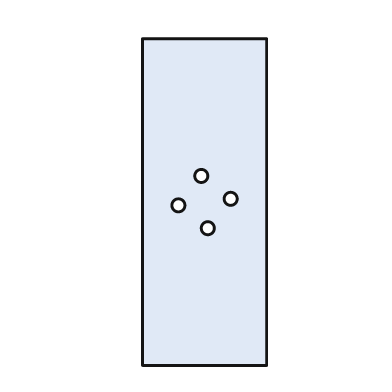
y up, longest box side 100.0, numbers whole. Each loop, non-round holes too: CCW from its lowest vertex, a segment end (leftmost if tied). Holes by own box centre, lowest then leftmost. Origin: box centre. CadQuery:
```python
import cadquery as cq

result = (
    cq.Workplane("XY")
    .moveTo(-19.0, -50.0)
    .lineTo(19.0, -50.0)
    .lineTo(19.0, 50.0)
    .lineTo(-19.0, 50.0)
    .close()
    .moveTo(1.0, -8.0)
    .circle(2.0)
    .moveTo(-8.0, -1.0)
    .circle(2.0)
    .moveTo(8.0, 1.0)
    .circle(2.0)
    .moveTo(-1.0, 8.0)
    .circle(2.0)
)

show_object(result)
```